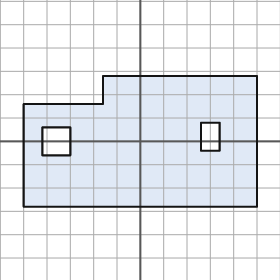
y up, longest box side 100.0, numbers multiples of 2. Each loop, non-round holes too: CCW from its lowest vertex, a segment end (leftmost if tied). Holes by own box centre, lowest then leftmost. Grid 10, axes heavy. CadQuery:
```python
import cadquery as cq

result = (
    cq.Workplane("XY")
    .moveTo(-50.0, -28.0)
    .lineTo(50.0, -28.0)
    .lineTo(50.0, 28.0)
    .lineTo(-16.0, 28.0)
    .lineTo(-16.0, 16.0)
    .lineTo(-50.0, 16.0)
    .close()
    .moveTo(-42.0, -6.0)
    .lineTo(-30.0, -6.0)
    .lineTo(-30.0, 6.0)
    .lineTo(-42.0, 6.0)
    .close()
    .moveTo(26.0, -4.0)
    .lineTo(34.0, -4.0)
    .lineTo(34.0, 8.0)
    .lineTo(26.0, 8.0)
    .close()
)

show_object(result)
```